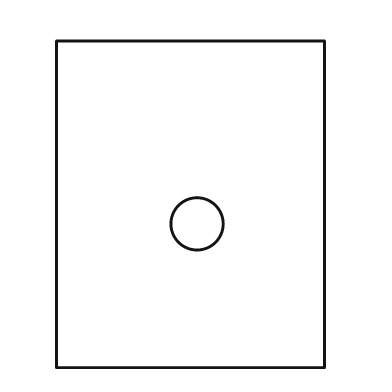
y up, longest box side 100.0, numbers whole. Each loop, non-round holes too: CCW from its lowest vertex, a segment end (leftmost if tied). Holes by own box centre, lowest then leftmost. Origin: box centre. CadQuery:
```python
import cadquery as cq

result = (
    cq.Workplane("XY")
    .moveTo(-41.0, -50.0)
    .lineTo(41.0, -50.0)
    .lineTo(41.0, 50.0)
    .lineTo(-41.0, 50.0)
    .close()
    .moveTo(2.0, -6.0)
    .circle(8.0)
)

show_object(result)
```